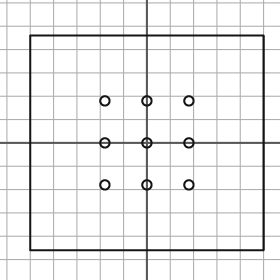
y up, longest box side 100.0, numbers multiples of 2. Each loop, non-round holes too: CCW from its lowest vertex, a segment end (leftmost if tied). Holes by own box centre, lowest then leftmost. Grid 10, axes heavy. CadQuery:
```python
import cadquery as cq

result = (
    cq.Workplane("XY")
    .moveTo(-50.0, -46.0)
    .lineTo(50.0, -46.0)
    .lineTo(50.0, 46.0)
    .lineTo(-50.0, 46.0)
    .close()
    .moveTo(-18.0, -18.0)
    .circle(2.0)
    .moveTo(0.0, -18.0)
    .circle(2.0)
    .moveTo(18.0, -18.0)
    .circle(2.0)
    .moveTo(-18.0, 0.0)
    .circle(2.0)
    .moveTo(0.0, 0.0)
    .circle(2.0)
    .moveTo(18.0, 0.0)
    .circle(2.0)
    .moveTo(-18.0, 18.0)
    .circle(2.0)
    .moveTo(0.0, 18.0)
    .circle(2.0)
    .moveTo(18.0, 18.0)
    .circle(2.0)
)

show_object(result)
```